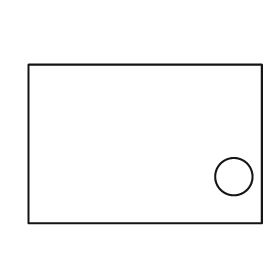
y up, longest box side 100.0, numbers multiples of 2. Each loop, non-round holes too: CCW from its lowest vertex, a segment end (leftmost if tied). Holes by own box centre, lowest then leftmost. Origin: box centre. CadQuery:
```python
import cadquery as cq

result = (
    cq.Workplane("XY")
    .moveTo(-50.0, -34.0)
    .lineTo(50.0, -34.0)
    .lineTo(50.0, 34.0)
    .lineTo(-50.0, 34.0)
    .close()
    .moveTo(38.0, -14.0)
    .circle(8.0)
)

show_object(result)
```